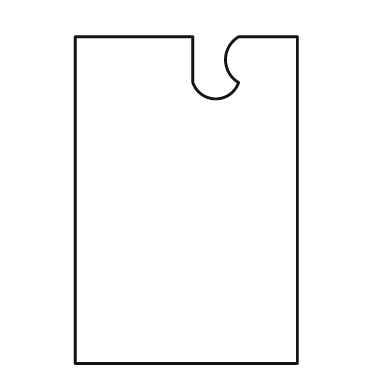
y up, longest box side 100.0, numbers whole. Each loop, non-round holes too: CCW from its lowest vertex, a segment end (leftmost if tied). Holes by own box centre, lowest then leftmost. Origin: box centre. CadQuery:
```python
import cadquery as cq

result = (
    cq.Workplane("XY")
    .moveTo(-34.0, -50.0)
    .lineTo(34.0, -50.0)
    .lineTo(34.0, 50.0)
    .lineTo(16.0, 50.0)
    .threePointArc((12.0, 43.0), (16.0, 36.0))
    .threePointArc((9.0, 31.0), (2.0, 36.0))
    .lineTo(2.0, 50.0)
    .lineTo(-34.0, 50.0)
    .close()
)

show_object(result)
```